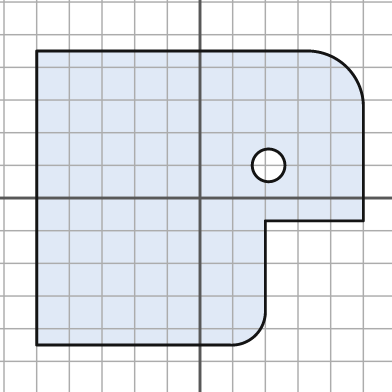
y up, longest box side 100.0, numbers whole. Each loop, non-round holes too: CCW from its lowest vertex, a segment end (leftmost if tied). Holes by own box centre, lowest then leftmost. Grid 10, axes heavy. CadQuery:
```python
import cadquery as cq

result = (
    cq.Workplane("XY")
    .moveTo(-50.0, -45.0)
    .lineTo(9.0, -45.0)
    .threePointArc((17.0, -42.0), (20.0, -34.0))
    .lineTo(20.0, -7.0)
    .lineTo(50.0, -7.0)
    .lineTo(50.0, 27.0)
    .threePointArc((45.0, 40.0), (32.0, 45.0))
    .lineTo(-50.0, 45.0)
    .close()
    .moveTo(21.0, 10.0)
    .circle(5.0)
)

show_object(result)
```